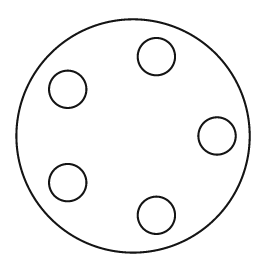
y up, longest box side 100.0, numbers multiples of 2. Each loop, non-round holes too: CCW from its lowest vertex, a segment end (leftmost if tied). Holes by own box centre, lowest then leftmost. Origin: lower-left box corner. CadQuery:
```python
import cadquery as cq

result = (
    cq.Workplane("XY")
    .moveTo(50.0, 50.0)
    .circle(50.0)
    .moveTo(60.0, 16.0)
    .circle(8.0)
    .moveTo(22.0, 30.0)
    .circle(8.0)
    .moveTo(86.0, 50.0)
    .circle(8.0)
    .moveTo(22.0, 70.0)
    .circle(8.0)
    .moveTo(60.0, 84.0)
    .circle(8.0)
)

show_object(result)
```